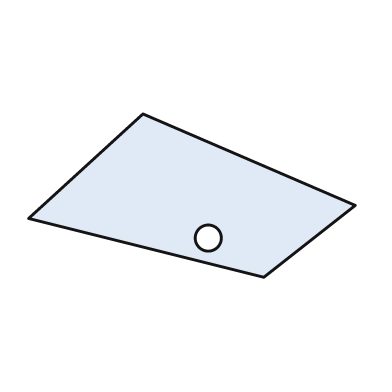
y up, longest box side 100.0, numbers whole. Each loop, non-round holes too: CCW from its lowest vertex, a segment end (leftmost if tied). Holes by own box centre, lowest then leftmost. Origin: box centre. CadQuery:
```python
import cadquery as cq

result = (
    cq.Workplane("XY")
    .moveTo(22.0, -25.0)
    .lineTo(50.0, -3.0)
    .lineTo(-15.0, 25.0)
    .lineTo(-50.0, -7.0)
    .close()
    .moveTo(5.0, -13.0)
    .circle(4.0)
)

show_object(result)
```